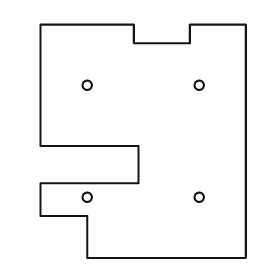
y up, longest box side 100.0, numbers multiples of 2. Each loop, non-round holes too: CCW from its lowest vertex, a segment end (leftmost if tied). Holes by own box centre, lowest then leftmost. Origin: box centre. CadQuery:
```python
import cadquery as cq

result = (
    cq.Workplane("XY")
    .moveTo(-24.0, -50.0)
    .lineTo(44.0, -50.0)
    .lineTo(44.0, 50.0)
    .lineTo(20.0, 50.0)
    .lineTo(20.0, 42.0)
    .lineTo(-4.0, 42.0)
    .lineTo(-4.0, 50.0)
    .lineTo(-44.0, 50.0)
    .lineTo(-44.0, -2.0)
    .lineTo(-2.0, -2.0)
    .lineTo(-2.0, -18.0)
    .lineTo(-44.0, -18.0)
    .lineTo(-44.0, -32.0)
    .lineTo(-24.0, -32.0)
    .close()
    .moveTo(-24.0, -24.0)
    .circle(2.0)
    .moveTo(24.0, -24.0)
    .circle(2.0)
    .moveTo(-24.0, 24.0)
    .circle(2.0)
    .moveTo(24.0, 24.0)
    .circle(2.0)
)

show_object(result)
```